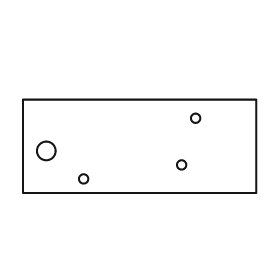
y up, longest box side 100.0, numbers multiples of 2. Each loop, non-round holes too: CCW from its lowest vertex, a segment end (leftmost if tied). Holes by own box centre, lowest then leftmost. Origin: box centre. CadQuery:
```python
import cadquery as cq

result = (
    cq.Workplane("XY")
    .moveTo(-50.0, -20.0)
    .lineTo(50.0, -20.0)
    .lineTo(50.0, 20.0)
    .lineTo(-50.0, 20.0)
    .close()
    .moveTo(-24.0, -14.0)
    .circle(2.0)
    .moveTo(18.0, -8.0)
    .circle(2.0)
    .moveTo(-40.0, -2.0)
    .circle(4.0)
    .moveTo(24.0, 12.0)
    .circle(2.0)
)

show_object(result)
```